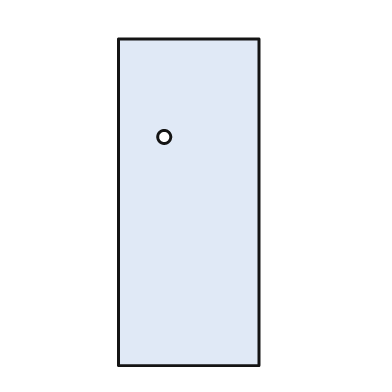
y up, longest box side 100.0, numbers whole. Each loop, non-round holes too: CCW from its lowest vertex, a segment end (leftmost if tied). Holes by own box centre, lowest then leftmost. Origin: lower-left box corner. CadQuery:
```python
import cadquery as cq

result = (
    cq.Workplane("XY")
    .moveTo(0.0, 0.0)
    .lineTo(43.0, 0.0)
    .lineTo(43.0, 100.0)
    .lineTo(0.0, 100.0)
    .close()
    .moveTo(14.0, 70.0)
    .circle(2.0)
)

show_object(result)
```